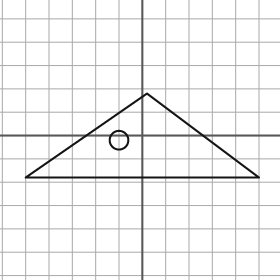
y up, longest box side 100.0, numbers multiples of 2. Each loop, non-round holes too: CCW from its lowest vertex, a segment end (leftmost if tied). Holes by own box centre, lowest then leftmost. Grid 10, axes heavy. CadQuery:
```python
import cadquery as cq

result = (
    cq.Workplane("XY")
    .moveTo(-50.0, -18.0)
    .lineTo(50.0, -18.0)
    .lineTo(2.0, 18.0)
    .close()
    .moveTo(-10.0, -2.0)
    .circle(4.0)
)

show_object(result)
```